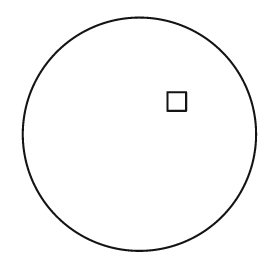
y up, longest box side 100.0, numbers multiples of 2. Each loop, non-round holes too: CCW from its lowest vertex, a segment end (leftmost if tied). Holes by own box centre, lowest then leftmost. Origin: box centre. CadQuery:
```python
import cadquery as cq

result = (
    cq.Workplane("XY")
    .moveTo(0.0, 0.0)
    .circle(50.0)
    .moveTo(12.0, 10.0)
    .lineTo(20.0, 10.0)
    .lineTo(20.0, 18.0)
    .lineTo(12.0, 18.0)
    .close()
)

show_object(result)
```